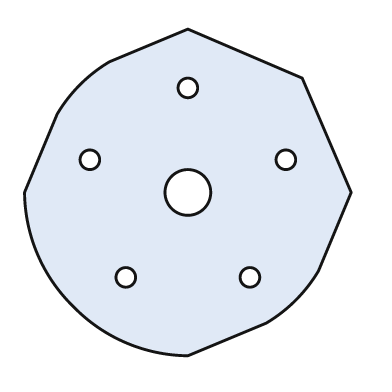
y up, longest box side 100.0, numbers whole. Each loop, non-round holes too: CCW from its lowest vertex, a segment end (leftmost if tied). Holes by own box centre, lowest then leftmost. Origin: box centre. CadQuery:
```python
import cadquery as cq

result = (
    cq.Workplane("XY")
    .moveTo(0.0, -50.0)
    .lineTo(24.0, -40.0)
    .threePointArc((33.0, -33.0), (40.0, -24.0))
    .lineTo(50.0, 0.0)
    .lineTo(35.0, 35.0)
    .lineTo(0.0, 50.0)
    .lineTo(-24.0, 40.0)
    .threePointArc((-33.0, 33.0), (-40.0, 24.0))
    .lineTo(-50.0, 0.0)
    .threePointArc((-46.0, -19.0), (-35.0, -35.0))
    .threePointArc((-19.0, -46.0), (0.0, -50.0))
    .close()
    .moveTo(-19.0, -26.0)
    .circle(3.0)
    .moveTo(19.0, -26.0)
    .circle(3.0)
    .moveTo(0.0, 0.0)
    .circle(7.0)
    .moveTo(-30.0, 10.0)
    .circle(3.0)
    .moveTo(30.0, 10.0)
    .circle(3.0)
    .moveTo(0.0, 32.0)
    .circle(3.0)
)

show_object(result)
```